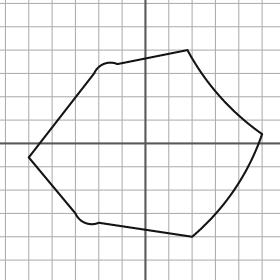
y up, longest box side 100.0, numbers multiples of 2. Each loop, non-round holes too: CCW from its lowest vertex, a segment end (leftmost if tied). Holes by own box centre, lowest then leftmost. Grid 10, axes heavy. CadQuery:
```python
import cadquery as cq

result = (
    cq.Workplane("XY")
    .moveTo(20.0, -40.0)
    .threePointArc((38.0, -20.0), (50.0, 4.0))
    .threePointArc((32.0, 20.0), (18.0, 40.0))
    .lineTo(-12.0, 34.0)
    .threePointArc((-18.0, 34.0), (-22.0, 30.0))
    .lineTo(-50.0, -6.0)
    .lineTo(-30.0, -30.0)
    .threePointArc((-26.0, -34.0), (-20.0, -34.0))
    .close()
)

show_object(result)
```